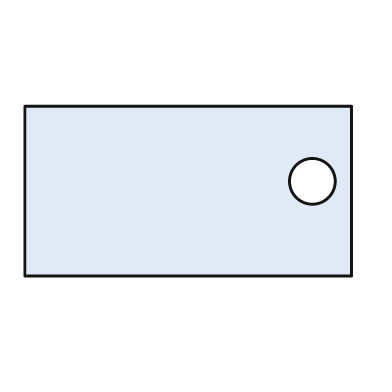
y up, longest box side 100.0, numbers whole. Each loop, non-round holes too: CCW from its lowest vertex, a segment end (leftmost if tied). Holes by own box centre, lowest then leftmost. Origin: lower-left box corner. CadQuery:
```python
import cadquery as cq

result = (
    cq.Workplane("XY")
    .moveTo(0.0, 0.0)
    .lineTo(100.0, 0.0)
    .lineTo(100.0, 52.0)
    .lineTo(0.0, 52.0)
    .close()
    .moveTo(88.0, 29.0)
    .circle(7.0)
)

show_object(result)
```